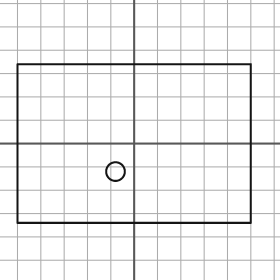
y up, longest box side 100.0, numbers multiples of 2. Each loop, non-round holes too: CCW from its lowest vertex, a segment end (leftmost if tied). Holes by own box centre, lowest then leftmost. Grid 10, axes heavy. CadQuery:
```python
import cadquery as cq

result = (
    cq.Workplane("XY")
    .moveTo(-50.0, -34.0)
    .lineTo(50.0, -34.0)
    .lineTo(50.0, 34.0)
    .lineTo(-50.0, 34.0)
    .close()
    .moveTo(-8.0, -12.0)
    .circle(4.0)
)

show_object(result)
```